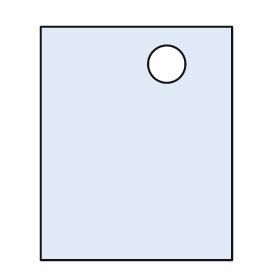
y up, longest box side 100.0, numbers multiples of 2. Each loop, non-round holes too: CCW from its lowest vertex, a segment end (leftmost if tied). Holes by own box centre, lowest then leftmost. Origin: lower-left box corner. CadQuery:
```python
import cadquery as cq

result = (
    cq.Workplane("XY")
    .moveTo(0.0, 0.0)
    .lineTo(82.0, 0.0)
    .lineTo(82.0, 100.0)
    .lineTo(0.0, 100.0)
    .close()
    .moveTo(54.0, 84.0)
    .circle(8.0)
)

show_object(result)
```